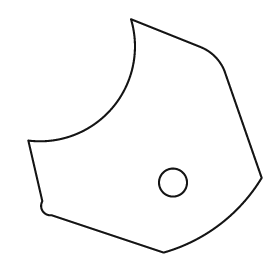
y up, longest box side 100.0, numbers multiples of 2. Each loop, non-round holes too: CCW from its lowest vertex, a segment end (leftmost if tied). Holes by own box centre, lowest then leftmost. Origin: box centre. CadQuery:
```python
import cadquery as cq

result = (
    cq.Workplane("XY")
    .moveTo(8.0, -50.0)
    .threePointArc((32.0, -38.0), (50.0, -18.0))
    .lineTo(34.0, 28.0)
    .threePointArc((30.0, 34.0), (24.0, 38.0))
    .lineTo(-6.0, 50.0)
    .threePointArc((-14.0, 12.0), (-50.0, -2.0))
    .lineTo(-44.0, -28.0)
    .threePointArc((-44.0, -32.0), (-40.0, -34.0))
    .close()
    .moveTo(12.0, -20.0)
    .circle(6.0)
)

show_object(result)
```